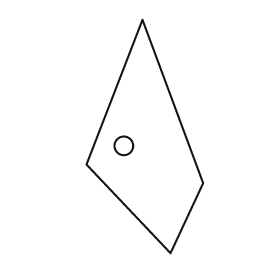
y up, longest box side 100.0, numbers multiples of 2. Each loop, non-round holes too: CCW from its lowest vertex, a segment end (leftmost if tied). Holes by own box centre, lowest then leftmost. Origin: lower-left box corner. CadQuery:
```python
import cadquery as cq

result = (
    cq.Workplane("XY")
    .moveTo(36.0, 0.0)
    .lineTo(50.0, 30.0)
    .lineTo(24.0, 100.0)
    .lineTo(0.0, 38.0)
    .close()
    .moveTo(16.0, 46.0)
    .circle(4.0)
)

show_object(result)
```